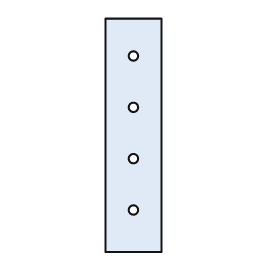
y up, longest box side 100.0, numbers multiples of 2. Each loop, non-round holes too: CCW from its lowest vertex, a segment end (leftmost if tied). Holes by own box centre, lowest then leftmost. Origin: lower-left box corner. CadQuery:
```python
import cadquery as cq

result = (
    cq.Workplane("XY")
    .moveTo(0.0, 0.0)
    .lineTo(24.0, 0.0)
    .lineTo(24.0, 100.0)
    .lineTo(0.0, 100.0)
    .close()
    .moveTo(12.0, 18.0)
    .circle(2.0)
    .moveTo(12.0, 40.0)
    .circle(2.0)
    .moveTo(12.0, 62.0)
    .circle(2.0)
    .moveTo(12.0, 84.0)
    .circle(2.0)
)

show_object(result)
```